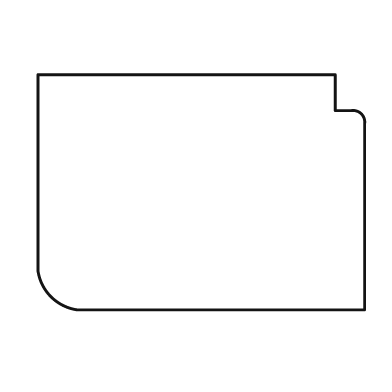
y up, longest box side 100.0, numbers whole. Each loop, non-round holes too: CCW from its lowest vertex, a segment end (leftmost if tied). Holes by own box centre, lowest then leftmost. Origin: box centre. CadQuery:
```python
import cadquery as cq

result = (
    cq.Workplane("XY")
    .moveTo(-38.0, -36.0)
    .lineTo(50.0, -36.0)
    .lineTo(50.0, 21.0)
    .threePointArc((49.0, 24.0), (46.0, 25.0))
    .lineTo(41.0, 25.0)
    .lineTo(41.0, 36.0)
    .lineTo(-50.0, 36.0)
    .lineTo(-50.0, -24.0)
    .threePointArc((-46.0, -32.0), (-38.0, -36.0))
    .close()
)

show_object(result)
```